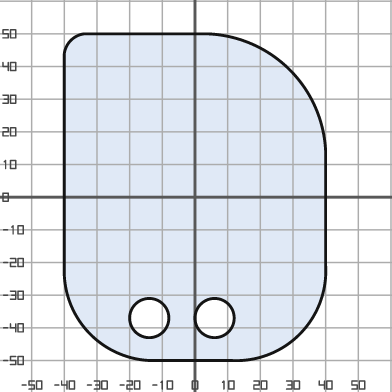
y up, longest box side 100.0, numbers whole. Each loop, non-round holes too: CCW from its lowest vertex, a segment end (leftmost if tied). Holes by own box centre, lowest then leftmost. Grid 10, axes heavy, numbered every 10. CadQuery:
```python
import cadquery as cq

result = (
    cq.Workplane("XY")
    .moveTo(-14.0, -50.0)
    .lineTo(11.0, -50.0)
    .threePointArc((32.0, -42.0), (40.0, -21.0))
    .lineTo(40.0, 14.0)
    .threePointArc((29.0, 39.0), (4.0, 50.0))
    .lineTo(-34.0, 50.0)
    .threePointArc((-38.0, 48.0), (-40.0, 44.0))
    .lineTo(-40.0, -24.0)
    .threePointArc((-32.0, -42.0), (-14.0, -50.0))
    .close()
    .moveTo(-14.0, -37.0)
    .circle(6.0)
    .moveTo(6.0, -37.0)
    .circle(6.0)
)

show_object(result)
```